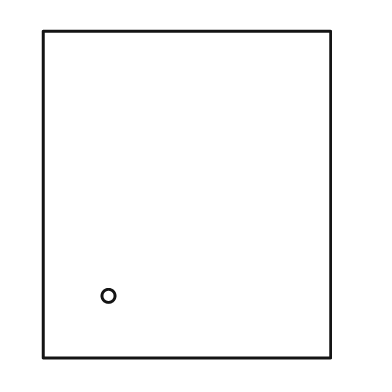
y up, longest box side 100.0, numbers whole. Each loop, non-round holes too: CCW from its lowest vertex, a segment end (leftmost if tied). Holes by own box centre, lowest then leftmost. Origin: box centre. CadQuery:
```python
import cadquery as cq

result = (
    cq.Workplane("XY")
    .moveTo(-44.0, -50.0)
    .lineTo(44.0, -50.0)
    .lineTo(44.0, 50.0)
    .lineTo(-44.0, 50.0)
    .close()
    .moveTo(-24.0, -31.0)
    .circle(2.0)
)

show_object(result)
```